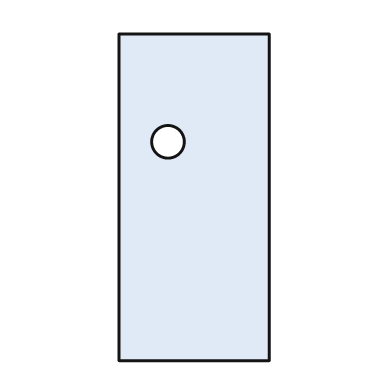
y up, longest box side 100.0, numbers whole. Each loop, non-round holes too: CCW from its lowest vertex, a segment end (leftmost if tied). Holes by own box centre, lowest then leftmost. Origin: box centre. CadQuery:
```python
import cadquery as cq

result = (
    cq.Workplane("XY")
    .moveTo(-23.0, -50.0)
    .lineTo(23.0, -50.0)
    .lineTo(23.0, 50.0)
    .lineTo(-23.0, 50.0)
    .close()
    .moveTo(-8.0, 17.0)
    .circle(5.0)
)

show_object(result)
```